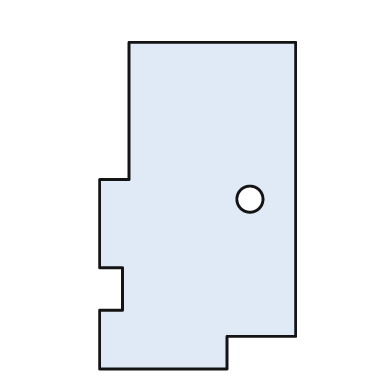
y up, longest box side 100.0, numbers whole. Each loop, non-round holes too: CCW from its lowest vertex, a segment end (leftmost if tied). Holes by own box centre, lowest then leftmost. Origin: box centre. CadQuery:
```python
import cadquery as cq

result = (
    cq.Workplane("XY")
    .moveTo(-30.0, -50.0)
    .lineTo(9.0, -50.0)
    .lineTo(9.0, -40.0)
    .lineTo(30.0, -40.0)
    .lineTo(30.0, 50.0)
    .lineTo(-21.0, 50.0)
    .lineTo(-21.0, 8.0)
    .lineTo(-30.0, 8.0)
    .lineTo(-30.0, -19.0)
    .lineTo(-23.0, -19.0)
    .lineTo(-23.0, -32.0)
    .lineTo(-30.0, -32.0)
    .close()
    .moveTo(16.0, 2.0)
    .circle(4.0)
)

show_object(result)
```